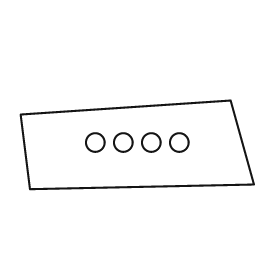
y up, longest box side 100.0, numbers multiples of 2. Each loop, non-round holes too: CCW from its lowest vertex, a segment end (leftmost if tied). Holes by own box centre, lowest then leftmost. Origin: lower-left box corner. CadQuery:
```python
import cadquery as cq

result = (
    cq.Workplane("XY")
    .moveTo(4.0, 0.0)
    .lineTo(100.0, 2.0)
    .lineTo(90.0, 38.0)
    .lineTo(0.0, 32.0)
    .close()
    .moveTo(32.0, 20.0)
    .circle(4.0)
    .moveTo(44.0, 20.0)
    .circle(4.0)
    .moveTo(56.0, 20.0)
    .circle(4.0)
    .moveTo(68.0, 20.0)
    .circle(4.0)
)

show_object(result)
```